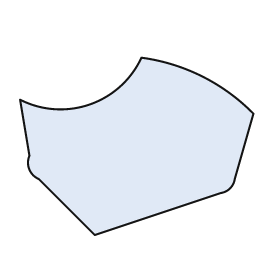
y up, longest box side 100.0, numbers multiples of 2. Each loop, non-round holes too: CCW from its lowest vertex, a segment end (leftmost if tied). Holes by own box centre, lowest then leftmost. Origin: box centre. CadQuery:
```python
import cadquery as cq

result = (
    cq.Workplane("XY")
    .moveTo(-18.0, -38.0)
    .lineTo(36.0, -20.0)
    .threePointArc((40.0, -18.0), (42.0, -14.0))
    .lineTo(50.0, 14.0)
    .threePointArc((28.0, 30.0), (2.0, 38.0))
    .threePointArc((-20.0, 18.0), (-50.0, 20.0))
    .lineTo(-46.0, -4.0)
    .threePointArc((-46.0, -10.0), (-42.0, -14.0))
    .close()
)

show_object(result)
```